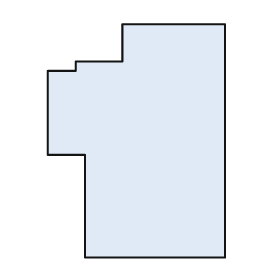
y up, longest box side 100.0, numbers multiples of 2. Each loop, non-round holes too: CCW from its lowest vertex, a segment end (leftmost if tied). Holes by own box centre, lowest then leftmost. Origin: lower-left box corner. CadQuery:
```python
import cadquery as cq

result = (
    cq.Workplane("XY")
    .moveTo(16.0, 0.0)
    .lineTo(76.0, 0.0)
    .lineTo(76.0, 100.0)
    .lineTo(32.0, 100.0)
    .lineTo(32.0, 84.0)
    .lineTo(12.0, 84.0)
    .lineTo(12.0, 80.0)
    .lineTo(0.0, 80.0)
    .lineTo(0.0, 44.0)
    .lineTo(16.0, 44.0)
    .close()
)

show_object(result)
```